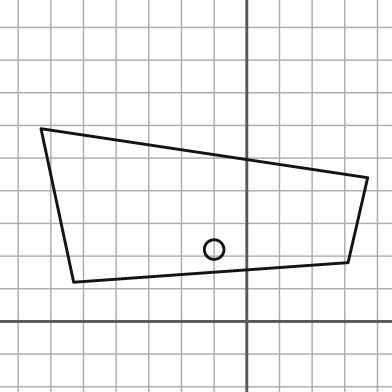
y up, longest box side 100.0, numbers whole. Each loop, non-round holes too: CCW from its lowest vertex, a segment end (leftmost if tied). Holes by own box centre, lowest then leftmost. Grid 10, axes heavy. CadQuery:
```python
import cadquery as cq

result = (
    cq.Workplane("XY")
    .moveTo(-53.0, 12.0)
    .lineTo(31.0, 18.0)
    .lineTo(37.0, 44.0)
    .lineTo(-63.0, 59.0)
    .close()
    .moveTo(-10.0, 22.0)
    .circle(3.0)
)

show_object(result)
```